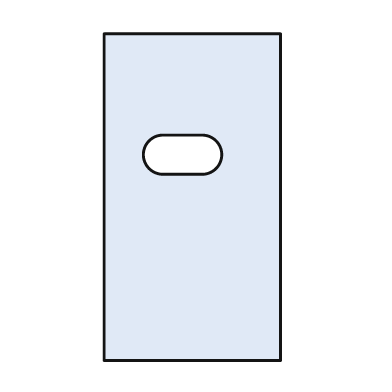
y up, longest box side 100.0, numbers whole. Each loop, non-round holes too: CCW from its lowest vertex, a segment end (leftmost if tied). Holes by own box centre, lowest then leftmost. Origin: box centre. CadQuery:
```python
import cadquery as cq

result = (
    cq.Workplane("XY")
    .moveTo(-27.0, -50.0)
    .lineTo(27.0, -50.0)
    .lineTo(27.0, 50.0)
    .lineTo(-27.0, 50.0)
    .close()
    .moveTo(-9.0, 7.0)
    .lineTo(3.0, 7.0)
    .threePointArc((9.0, 13.0), (3.0, 19.0))
    .lineTo(-9.0, 19.0)
    .threePointArc((-15.0, 13.0), (-9.0, 7.0))
    .close()
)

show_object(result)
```